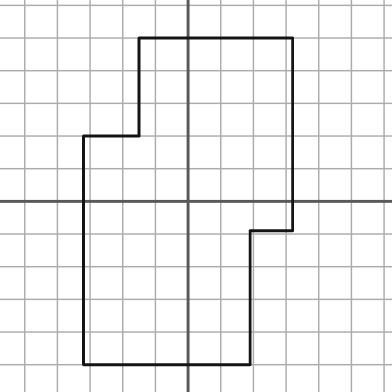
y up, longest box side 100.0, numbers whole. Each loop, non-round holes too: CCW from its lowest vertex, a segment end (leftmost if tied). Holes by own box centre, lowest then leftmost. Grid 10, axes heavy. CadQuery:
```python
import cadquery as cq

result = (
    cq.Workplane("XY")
    .moveTo(-32.0, -50.0)
    .lineTo(19.0, -50.0)
    .lineTo(19.0, -9.0)
    .lineTo(32.0, -9.0)
    .lineTo(32.0, 50.0)
    .lineTo(-15.0, 50.0)
    .lineTo(-15.0, 20.0)
    .lineTo(-32.0, 20.0)
    .close()
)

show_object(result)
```